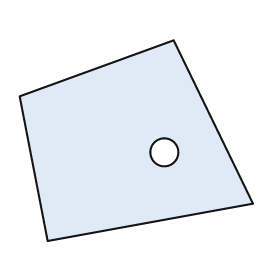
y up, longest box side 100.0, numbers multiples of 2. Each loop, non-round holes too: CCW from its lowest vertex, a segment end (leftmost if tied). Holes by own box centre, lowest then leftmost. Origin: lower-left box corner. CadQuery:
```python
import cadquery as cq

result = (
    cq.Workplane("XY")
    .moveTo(12.0, 0.0)
    .lineTo(100.0, 16.0)
    .lineTo(66.0, 86.0)
    .lineTo(0.0, 62.0)
    .close()
    .moveTo(62.0, 38.0)
    .circle(6.0)
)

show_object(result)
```